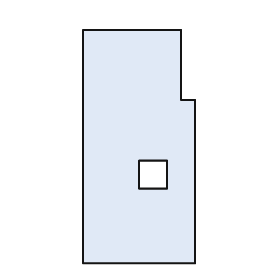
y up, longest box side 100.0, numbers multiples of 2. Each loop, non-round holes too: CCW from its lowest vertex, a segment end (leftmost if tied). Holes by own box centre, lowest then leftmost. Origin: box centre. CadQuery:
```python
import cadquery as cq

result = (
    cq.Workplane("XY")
    .moveTo(-24.0, -50.0)
    .lineTo(24.0, -50.0)
    .lineTo(24.0, 20.0)
    .lineTo(18.0, 20.0)
    .lineTo(18.0, 50.0)
    .lineTo(-24.0, 50.0)
    .close()
    .moveTo(0.0, -18.0)
    .lineTo(12.0, -18.0)
    .lineTo(12.0, -6.0)
    .lineTo(0.0, -6.0)
    .close()
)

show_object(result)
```